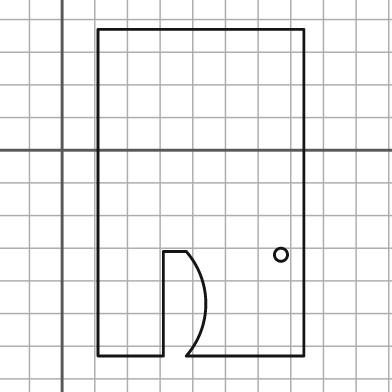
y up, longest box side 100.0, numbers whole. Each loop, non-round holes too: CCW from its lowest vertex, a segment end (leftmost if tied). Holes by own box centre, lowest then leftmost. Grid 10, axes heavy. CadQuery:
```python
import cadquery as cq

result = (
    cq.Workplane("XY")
    .moveTo(11.0, -63.0)
    .lineTo(31.0, -63.0)
    .lineTo(31.0, -31.0)
    .lineTo(38.0, -31.0)
    .threePointArc((44.0, -47.0), (38.0, -63.0))
    .lineTo(74.0, -63.0)
    .lineTo(74.0, 37.0)
    .lineTo(11.0, 37.0)
    .close()
    .moveTo(67.0, -32.0)
    .circle(2.0)
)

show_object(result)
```